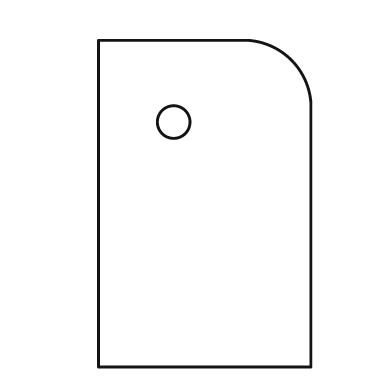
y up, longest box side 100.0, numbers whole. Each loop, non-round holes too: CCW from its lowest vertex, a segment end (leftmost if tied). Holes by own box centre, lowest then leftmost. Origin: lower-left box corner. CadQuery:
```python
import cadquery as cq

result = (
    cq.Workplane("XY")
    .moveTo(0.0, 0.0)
    .lineTo(65.0, 0.0)
    .lineTo(65.0, 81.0)
    .threePointArc((59.0, 94.0), (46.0, 100.0))
    .lineTo(0.0, 100.0)
    .close()
    .moveTo(23.0, 75.0)
    .circle(5.0)
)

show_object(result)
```